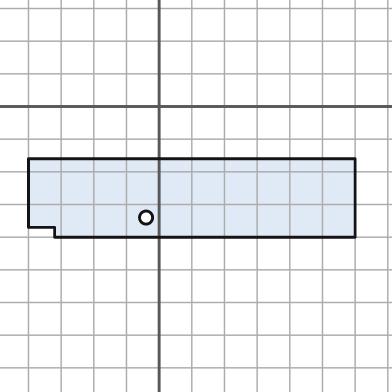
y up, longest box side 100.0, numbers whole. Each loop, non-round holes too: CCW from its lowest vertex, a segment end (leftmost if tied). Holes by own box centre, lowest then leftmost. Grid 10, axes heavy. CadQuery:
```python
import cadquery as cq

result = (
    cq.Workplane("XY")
    .moveTo(-32.0, -40.0)
    .lineTo(60.0, -40.0)
    .lineTo(60.0, -16.0)
    .lineTo(-40.0, -16.0)
    .lineTo(-40.0, -37.0)
    .lineTo(-32.0, -37.0)
    .close()
    .moveTo(-4.0, -34.0)
    .circle(2.0)
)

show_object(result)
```